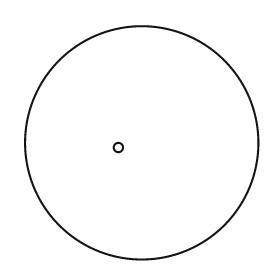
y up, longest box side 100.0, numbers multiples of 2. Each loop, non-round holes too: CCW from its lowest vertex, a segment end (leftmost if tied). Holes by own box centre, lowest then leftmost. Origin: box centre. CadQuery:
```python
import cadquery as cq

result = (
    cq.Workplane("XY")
    .moveTo(0.0, 0.0)
    .circle(50.0)
    .moveTo(-10.0, -2.0)
    .circle(2.0)
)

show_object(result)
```